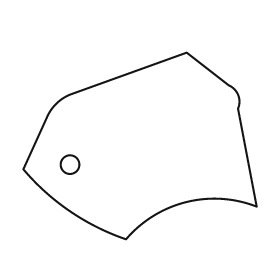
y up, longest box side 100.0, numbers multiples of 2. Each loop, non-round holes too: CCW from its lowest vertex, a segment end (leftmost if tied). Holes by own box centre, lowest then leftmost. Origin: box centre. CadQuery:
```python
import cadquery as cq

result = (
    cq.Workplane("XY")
    .moveTo(-6.0, -40.0)
    .threePointArc((20.0, -24.0), (50.0, -26.0))
    .lineTo(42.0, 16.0)
    .threePointArc((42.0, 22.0), (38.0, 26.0))
    .lineTo(20.0, 40.0)
    .lineTo(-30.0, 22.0)
    .threePointArc((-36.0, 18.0), (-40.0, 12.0))
    .lineTo(-50.0, -10.0)
    .threePointArc((-30.0, -28.0), (-6.0, -40.0))
    .close()
    .moveTo(-30.0, -8.0)
    .circle(4.0)
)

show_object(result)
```